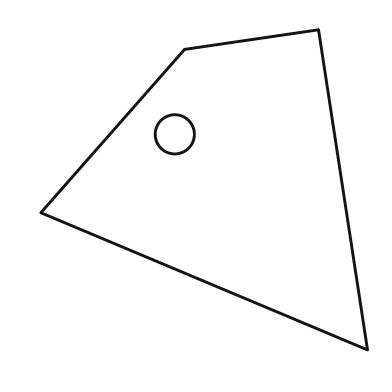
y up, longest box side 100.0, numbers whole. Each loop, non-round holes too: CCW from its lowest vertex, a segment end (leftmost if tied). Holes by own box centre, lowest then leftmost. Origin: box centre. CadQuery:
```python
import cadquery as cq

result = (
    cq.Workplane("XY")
    .moveTo(50.0, -49.0)
    .lineTo(35.0, 49.0)
    .lineTo(-6.0, 43.0)
    .lineTo(-50.0, -7.0)
    .close()
    .moveTo(-9.0, 17.0)
    .circle(6.0)
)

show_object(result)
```